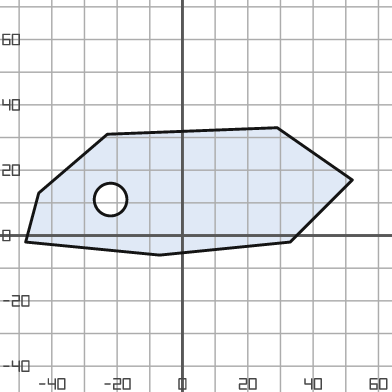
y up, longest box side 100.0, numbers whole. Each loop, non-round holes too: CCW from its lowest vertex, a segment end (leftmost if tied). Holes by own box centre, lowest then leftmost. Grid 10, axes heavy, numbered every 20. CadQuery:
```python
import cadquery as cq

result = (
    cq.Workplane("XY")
    .moveTo(-7.0, -6.0)
    .lineTo(33.0, -2.0)
    .lineTo(52.0, 17.0)
    .lineTo(29.0, 33.0)
    .lineTo(-23.0, 31.0)
    .lineTo(-44.0, 13.0)
    .lineTo(-48.0, -2.0)
    .close()
    .moveTo(-22.0, 11.0)
    .circle(5.0)
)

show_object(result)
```